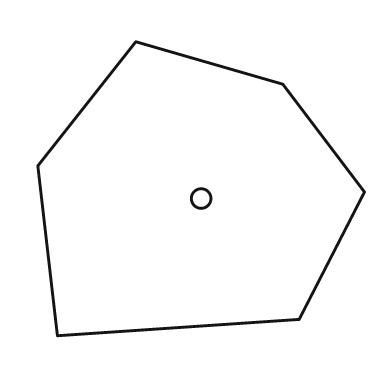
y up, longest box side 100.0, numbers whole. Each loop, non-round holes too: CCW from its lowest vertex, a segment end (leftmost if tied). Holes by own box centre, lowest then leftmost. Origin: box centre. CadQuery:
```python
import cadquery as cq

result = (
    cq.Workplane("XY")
    .moveTo(-44.0, -45.0)
    .lineTo(30.0, -40.0)
    .lineTo(50.0, -1.0)
    .lineTo(25.0, 32.0)
    .lineTo(-20.0, 45.0)
    .lineTo(-50.0, 7.0)
    .close()
    .moveTo(0.0, -3.0)
    .circle(3.0)
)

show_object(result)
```